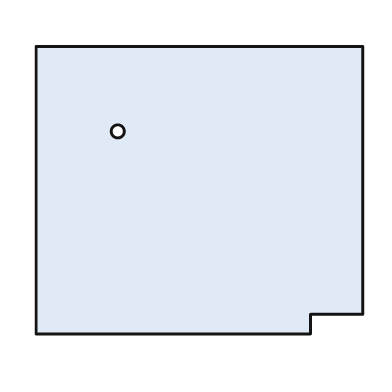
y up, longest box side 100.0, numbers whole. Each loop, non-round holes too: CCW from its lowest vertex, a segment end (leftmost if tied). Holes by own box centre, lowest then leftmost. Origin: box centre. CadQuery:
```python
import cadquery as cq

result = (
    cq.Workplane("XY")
    .moveTo(-50.0, -44.0)
    .lineTo(34.0, -44.0)
    .lineTo(34.0, -38.0)
    .lineTo(50.0, -38.0)
    .lineTo(50.0, 44.0)
    .lineTo(-50.0, 44.0)
    .close()
    .moveTo(-25.0, 18.0)
    .circle(2.0)
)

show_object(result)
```